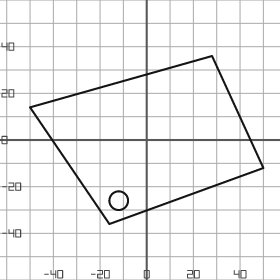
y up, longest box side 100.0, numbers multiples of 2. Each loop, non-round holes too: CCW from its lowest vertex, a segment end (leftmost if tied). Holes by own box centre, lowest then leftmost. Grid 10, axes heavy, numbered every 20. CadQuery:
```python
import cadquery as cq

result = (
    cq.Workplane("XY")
    .moveTo(-16.0, -36.0)
    .lineTo(50.0, -12.0)
    .lineTo(28.0, 36.0)
    .lineTo(-50.0, 14.0)
    .close()
    .moveTo(-12.0, -26.0)
    .circle(4.0)
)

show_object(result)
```